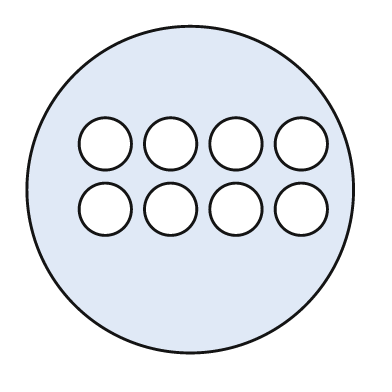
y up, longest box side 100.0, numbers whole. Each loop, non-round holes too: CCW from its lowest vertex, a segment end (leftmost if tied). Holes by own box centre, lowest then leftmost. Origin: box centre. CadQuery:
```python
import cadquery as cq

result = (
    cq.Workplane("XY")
    .moveTo(0.0, 0.0)
    .circle(50.0)
    .moveTo(-26.0, -6.0)
    .circle(8.0)
    .moveTo(-6.0, -6.0)
    .circle(8.0)
    .moveTo(14.0, -6.0)
    .circle(8.0)
    .moveTo(34.0, -6.0)
    .circle(8.0)
    .moveTo(-26.0, 14.0)
    .circle(8.0)
    .moveTo(-6.0, 14.0)
    .circle(8.0)
    .moveTo(14.0, 14.0)
    .circle(8.0)
    .moveTo(34.0, 14.0)
    .circle(8.0)
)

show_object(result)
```